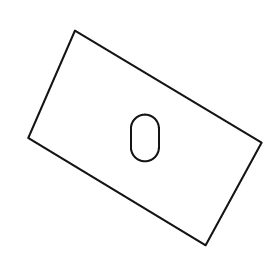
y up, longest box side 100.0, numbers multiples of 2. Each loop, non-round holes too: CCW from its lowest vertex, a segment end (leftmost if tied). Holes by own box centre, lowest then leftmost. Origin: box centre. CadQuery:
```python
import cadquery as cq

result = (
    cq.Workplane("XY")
    .moveTo(26.0, -46.0)
    .lineTo(50.0, -2.0)
    .lineTo(-30.0, 46.0)
    .lineTo(-50.0, 0.0)
    .close()
    .moveTo(-6.0, -4.0)
    .threePointArc((0.0, -10.0), (6.0, -4.0))
    .lineTo(6.0, 4.0)
    .threePointArc((0.0, 10.0), (-6.0, 4.0))
    .close()
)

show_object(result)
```